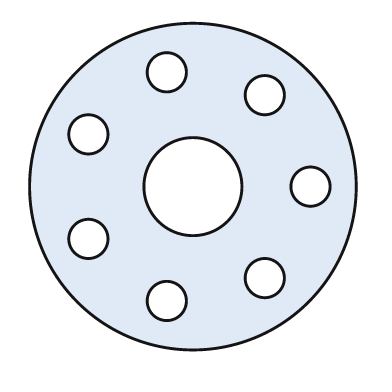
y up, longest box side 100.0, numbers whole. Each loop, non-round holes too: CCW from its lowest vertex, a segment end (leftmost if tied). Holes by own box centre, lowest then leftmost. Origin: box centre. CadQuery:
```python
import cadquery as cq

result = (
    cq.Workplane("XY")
    .moveTo(0.0, 0.0)
    .circle(50.0)
    .moveTo(-8.0, -35.0)
    .circle(6.0)
    .moveTo(22.0, -28.0)
    .circle(6.0)
    .moveTo(-32.0, -16.0)
    .circle(6.0)
    .moveTo(0.0, 0.0)
    .circle(15.0)
    .moveTo(36.0, 0.0)
    .circle(6.0)
    .moveTo(-32.0, 16.0)
    .circle(6.0)
    .moveTo(22.0, 28.0)
    .circle(6.0)
    .moveTo(-8.0, 35.0)
    .circle(6.0)
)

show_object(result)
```